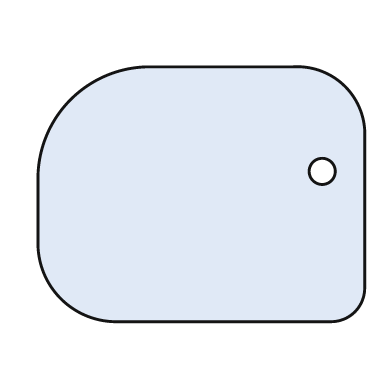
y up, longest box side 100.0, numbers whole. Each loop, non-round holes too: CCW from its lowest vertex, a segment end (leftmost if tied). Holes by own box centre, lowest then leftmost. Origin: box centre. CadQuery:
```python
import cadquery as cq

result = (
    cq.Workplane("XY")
    .moveTo(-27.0, -39.0)
    .lineTo(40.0, -39.0)
    .threePointArc((47.0, -36.0), (50.0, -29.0))
    .lineTo(50.0, 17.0)
    .threePointArc((44.0, 33.0), (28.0, 39.0))
    .lineTo(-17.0, 39.0)
    .threePointArc((-40.0, 29.0), (-50.0, 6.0))
    .lineTo(-50.0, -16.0)
    .threePointArc((-43.0, -32.0), (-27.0, -39.0))
    .close()
    .moveTo(37.0, 7.0)
    .circle(4.0)
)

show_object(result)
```